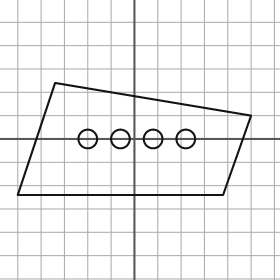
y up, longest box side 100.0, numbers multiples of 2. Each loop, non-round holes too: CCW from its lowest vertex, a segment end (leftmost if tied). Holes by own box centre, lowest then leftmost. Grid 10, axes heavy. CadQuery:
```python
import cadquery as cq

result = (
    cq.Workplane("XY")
    .moveTo(-50.0, -24.0)
    .lineTo(38.0, -24.0)
    .lineTo(50.0, 10.0)
    .lineTo(-34.0, 24.0)
    .close()
    .moveTo(-20.0, 0.0)
    .circle(4.0)
    .moveTo(-6.0, 0.0)
    .circle(4.0)
    .moveTo(8.0, 0.0)
    .circle(4.0)
    .moveTo(22.0, 0.0)
    .circle(4.0)
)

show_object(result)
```